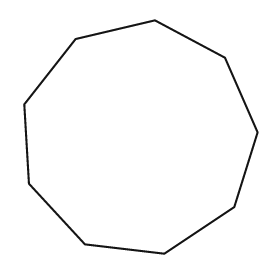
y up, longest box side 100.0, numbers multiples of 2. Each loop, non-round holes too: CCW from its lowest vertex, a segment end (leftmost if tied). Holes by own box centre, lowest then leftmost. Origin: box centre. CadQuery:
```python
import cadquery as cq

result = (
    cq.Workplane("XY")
    .moveTo(10.0, -50.0)
    .lineTo(40.0, -30.0)
    .lineTo(50.0, 2.0)
    .lineTo(36.0, 34.0)
    .lineTo(6.0, 50.0)
    .lineTo(-28.0, 42.0)
    .lineTo(-50.0, 14.0)
    .lineTo(-48.0, -20.0)
    .lineTo(-24.0, -46.0)
    .close()
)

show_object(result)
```